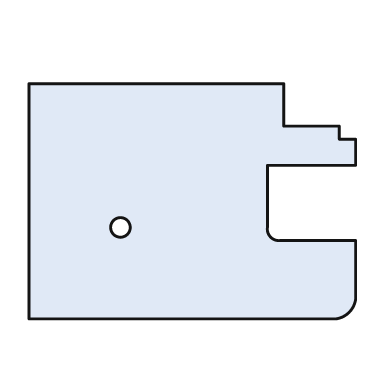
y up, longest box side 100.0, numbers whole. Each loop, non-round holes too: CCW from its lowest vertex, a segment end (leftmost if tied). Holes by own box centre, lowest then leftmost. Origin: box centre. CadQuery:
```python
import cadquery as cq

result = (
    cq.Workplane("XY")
    .moveTo(-50.0, -36.0)
    .lineTo(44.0, -36.0)
    .threePointArc((48.0, -34.0), (50.0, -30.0))
    .lineTo(50.0, -12.0)
    .lineTo(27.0, -12.0)
    .threePointArc((24.0, -11.0), (23.0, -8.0))
    .lineTo(23.0, 11.0)
    .lineTo(50.0, 11.0)
    .lineTo(50.0, 19.0)
    .lineTo(45.0, 19.0)
    .lineTo(45.0, 23.0)
    .lineTo(28.0, 23.0)
    .lineTo(28.0, 36.0)
    .lineTo(-50.0, 36.0)
    .close()
    .moveTo(-22.0, -8.0)
    .circle(3.0)
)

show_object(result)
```